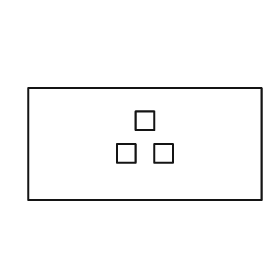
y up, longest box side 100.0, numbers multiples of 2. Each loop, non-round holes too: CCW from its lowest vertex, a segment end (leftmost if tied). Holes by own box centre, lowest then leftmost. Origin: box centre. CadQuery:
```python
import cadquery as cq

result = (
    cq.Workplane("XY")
    .moveTo(-50.0, -24.0)
    .lineTo(50.0, -24.0)
    .lineTo(50.0, 24.0)
    .lineTo(-50.0, 24.0)
    .close()
    .moveTo(-12.0, -8.0)
    .lineTo(-4.0, -8.0)
    .lineTo(-4.0, 0.0)
    .lineTo(-12.0, 0.0)
    .close()
    .moveTo(4.0, -8.0)
    .lineTo(12.0, -8.0)
    .lineTo(12.0, 0.0)
    .lineTo(4.0, 0.0)
    .close()
    .moveTo(-4.0, 6.0)
    .lineTo(4.0, 6.0)
    .lineTo(4.0, 14.0)
    .lineTo(-4.0, 14.0)
    .close()
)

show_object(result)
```